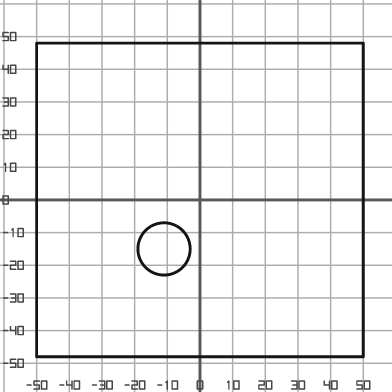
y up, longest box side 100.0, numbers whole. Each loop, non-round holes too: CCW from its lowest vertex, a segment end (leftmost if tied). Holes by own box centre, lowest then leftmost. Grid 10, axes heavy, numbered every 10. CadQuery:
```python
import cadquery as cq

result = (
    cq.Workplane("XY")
    .moveTo(-50.0, -48.0)
    .lineTo(50.0, -48.0)
    .lineTo(50.0, 48.0)
    .lineTo(-50.0, 48.0)
    .close()
    .moveTo(-11.0, -15.0)
    .circle(8.0)
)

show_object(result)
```